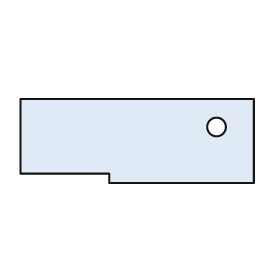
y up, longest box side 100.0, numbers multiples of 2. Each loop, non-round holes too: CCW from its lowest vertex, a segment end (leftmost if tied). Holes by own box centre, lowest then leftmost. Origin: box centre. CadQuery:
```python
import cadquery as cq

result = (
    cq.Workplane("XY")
    .moveTo(-12.0, -18.0)
    .lineTo(50.0, -18.0)
    .lineTo(50.0, 18.0)
    .lineTo(-50.0, 18.0)
    .lineTo(-50.0, -14.0)
    .lineTo(-12.0, -14.0)
    .close()
    .moveTo(34.0, 6.0)
    .circle(4.0)
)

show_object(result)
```